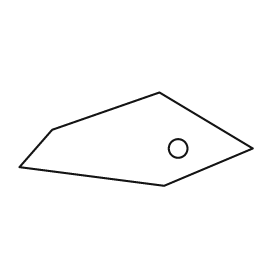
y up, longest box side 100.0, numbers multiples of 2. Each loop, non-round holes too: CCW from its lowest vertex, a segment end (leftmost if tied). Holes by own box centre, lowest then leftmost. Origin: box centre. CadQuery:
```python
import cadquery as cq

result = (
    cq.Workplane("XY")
    .moveTo(12.0, -20.0)
    .lineTo(50.0, -4.0)
    .lineTo(10.0, 20.0)
    .lineTo(-36.0, 4.0)
    .lineTo(-50.0, -12.0)
    .close()
    .moveTo(18.0, -4.0)
    .circle(4.0)
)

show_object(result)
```